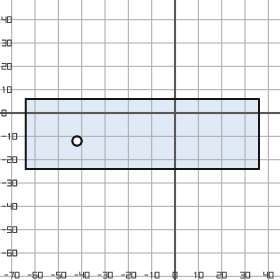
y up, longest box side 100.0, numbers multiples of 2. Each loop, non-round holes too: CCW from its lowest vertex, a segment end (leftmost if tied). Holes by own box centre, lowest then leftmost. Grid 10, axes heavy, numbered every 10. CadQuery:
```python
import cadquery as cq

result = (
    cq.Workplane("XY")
    .moveTo(-64.0, -24.0)
    .lineTo(36.0, -24.0)
    .lineTo(36.0, 6.0)
    .lineTo(-64.0, 6.0)
    .close()
    .moveTo(-42.0, -12.0)
    .circle(2.0)
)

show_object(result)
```